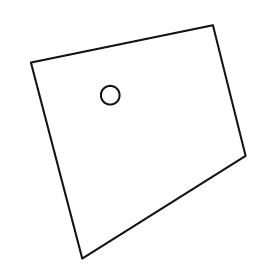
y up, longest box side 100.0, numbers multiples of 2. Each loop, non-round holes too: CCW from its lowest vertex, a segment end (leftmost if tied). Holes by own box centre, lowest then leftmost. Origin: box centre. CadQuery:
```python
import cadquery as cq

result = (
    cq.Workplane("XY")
    .moveTo(-24.0, -50.0)
    .lineTo(46.0, -6.0)
    .lineTo(32.0, 50.0)
    .lineTo(-46.0, 34.0)
    .close()
    .moveTo(-12.0, 20.0)
    .circle(4.0)
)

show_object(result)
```